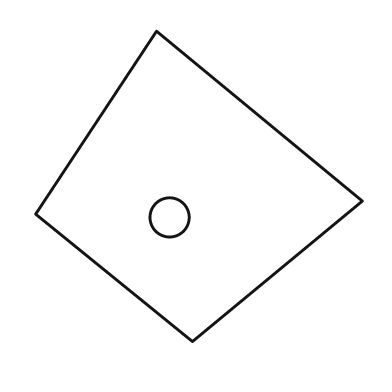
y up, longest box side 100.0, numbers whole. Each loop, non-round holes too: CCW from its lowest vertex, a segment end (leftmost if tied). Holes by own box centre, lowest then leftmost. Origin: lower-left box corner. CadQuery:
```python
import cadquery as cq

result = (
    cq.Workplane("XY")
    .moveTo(48.0, 0.0)
    .lineTo(100.0, 43.0)
    .lineTo(37.0, 95.0)
    .lineTo(0.0, 39.0)
    .close()
    .moveTo(41.0, 38.0)
    .circle(6.0)
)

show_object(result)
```